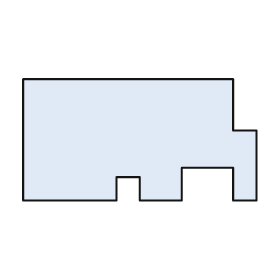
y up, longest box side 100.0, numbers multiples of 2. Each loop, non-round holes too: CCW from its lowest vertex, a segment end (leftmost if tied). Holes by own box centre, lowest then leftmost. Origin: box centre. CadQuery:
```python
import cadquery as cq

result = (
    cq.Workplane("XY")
    .moveTo(-50.0, -26.0)
    .lineTo(-10.0, -26.0)
    .lineTo(-10.0, -16.0)
    .lineTo(0.0, -16.0)
    .lineTo(0.0, -26.0)
    .lineTo(18.0, -26.0)
    .lineTo(18.0, -12.0)
    .lineTo(40.0, -12.0)
    .lineTo(40.0, -26.0)
    .lineTo(50.0, -26.0)
    .lineTo(50.0, 4.0)
    .lineTo(40.0, 4.0)
    .lineTo(40.0, 26.0)
    .lineTo(-50.0, 26.0)
    .close()
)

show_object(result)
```